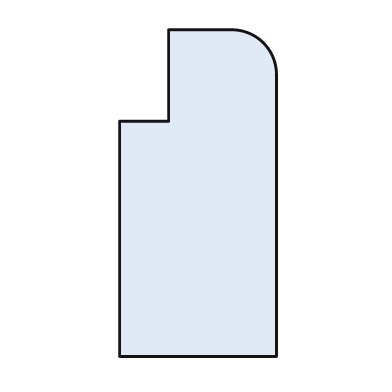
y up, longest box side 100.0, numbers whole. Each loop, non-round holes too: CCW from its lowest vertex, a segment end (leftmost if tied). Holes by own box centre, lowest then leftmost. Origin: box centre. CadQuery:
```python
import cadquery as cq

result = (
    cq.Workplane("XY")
    .moveTo(-24.0, -50.0)
    .lineTo(24.0, -50.0)
    .lineTo(24.0, 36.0)
    .threePointArc((20.0, 46.0), (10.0, 50.0))
    .lineTo(-9.0, 50.0)
    .lineTo(-9.0, 22.0)
    .lineTo(-24.0, 22.0)
    .close()
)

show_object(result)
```